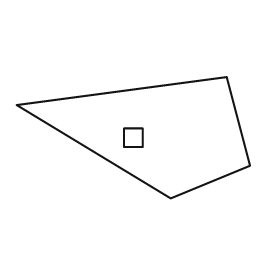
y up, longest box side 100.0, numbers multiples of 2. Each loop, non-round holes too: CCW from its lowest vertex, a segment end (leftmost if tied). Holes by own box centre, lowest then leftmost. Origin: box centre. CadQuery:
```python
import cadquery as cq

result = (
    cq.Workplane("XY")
    .moveTo(16.0, -26.0)
    .lineTo(50.0, -12.0)
    .lineTo(40.0, 26.0)
    .lineTo(-50.0, 14.0)
    .close()
    .moveTo(-4.0, -4.0)
    .lineTo(4.0, -4.0)
    .lineTo(4.0, 4.0)
    .lineTo(-4.0, 4.0)
    .close()
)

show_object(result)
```